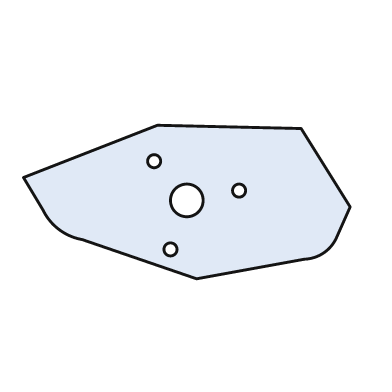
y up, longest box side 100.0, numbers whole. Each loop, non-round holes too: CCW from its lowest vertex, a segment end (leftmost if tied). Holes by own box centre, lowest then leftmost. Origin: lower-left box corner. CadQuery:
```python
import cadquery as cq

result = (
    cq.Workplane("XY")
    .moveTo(53.0, 0.0)
    .lineTo(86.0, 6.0)
    .threePointArc((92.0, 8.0), (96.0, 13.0))
    .lineTo(100.0, 22.0)
    .lineTo(85.0, 46.0)
    .lineTo(41.0, 47.0)
    .lineTo(0.0, 31.0)
    .lineTo(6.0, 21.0)
    .threePointArc((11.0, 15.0), (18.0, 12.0))
    .close()
    .moveTo(45.0, 9.0)
    .circle(2.0)
    .moveTo(50.0, 24.0)
    .circle(5.0)
    .moveTo(66.0, 27.0)
    .circle(2.0)
    .moveTo(40.0, 36.0)
    .circle(2.0)
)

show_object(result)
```